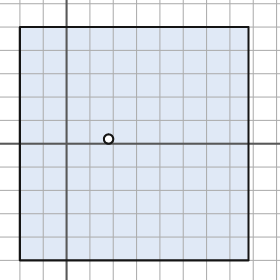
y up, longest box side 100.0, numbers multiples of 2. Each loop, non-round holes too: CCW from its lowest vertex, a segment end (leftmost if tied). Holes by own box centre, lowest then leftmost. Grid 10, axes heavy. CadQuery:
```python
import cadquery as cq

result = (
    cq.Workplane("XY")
    .moveTo(-20.0, -50.0)
    .lineTo(78.0, -50.0)
    .lineTo(78.0, 50.0)
    .lineTo(-20.0, 50.0)
    .close()
    .moveTo(18.0, 2.0)
    .circle(2.0)
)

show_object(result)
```